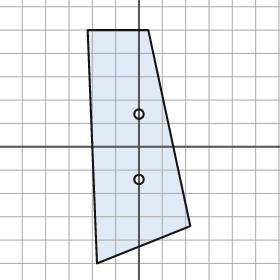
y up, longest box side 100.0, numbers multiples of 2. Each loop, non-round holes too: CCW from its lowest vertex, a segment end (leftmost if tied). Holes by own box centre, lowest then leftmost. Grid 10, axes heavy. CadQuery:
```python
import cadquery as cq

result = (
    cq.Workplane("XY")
    .moveTo(-18.0, -50.0)
    .lineTo(22.0, -34.0)
    .lineTo(4.0, 50.0)
    .lineTo(-22.0, 50.0)
    .close()
    .moveTo(0.0, -14.0)
    .circle(2.0)
    .moveTo(0.0, 14.0)
    .circle(2.0)
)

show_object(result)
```